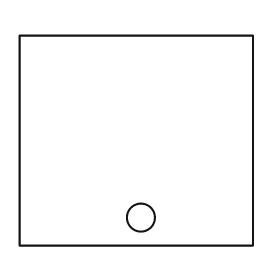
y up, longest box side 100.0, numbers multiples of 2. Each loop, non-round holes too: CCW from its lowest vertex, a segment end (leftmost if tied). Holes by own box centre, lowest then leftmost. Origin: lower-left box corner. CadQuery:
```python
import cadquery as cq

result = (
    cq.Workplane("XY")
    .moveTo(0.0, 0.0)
    .lineTo(100.0, 0.0)
    .lineTo(100.0, 90.0)
    .lineTo(0.0, 90.0)
    .close()
    .moveTo(52.0, 12.0)
    .circle(6.0)
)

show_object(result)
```